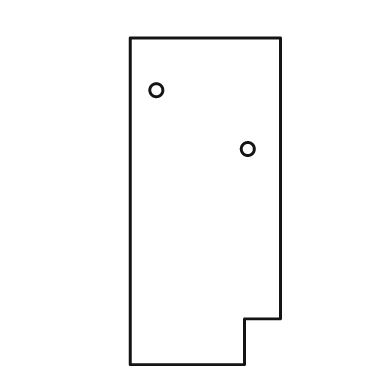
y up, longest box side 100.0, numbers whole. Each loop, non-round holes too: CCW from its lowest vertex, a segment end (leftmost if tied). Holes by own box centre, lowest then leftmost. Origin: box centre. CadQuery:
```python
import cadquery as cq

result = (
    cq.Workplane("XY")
    .moveTo(-23.0, -50.0)
    .lineTo(12.0, -50.0)
    .lineTo(12.0, -36.0)
    .lineTo(23.0, -36.0)
    .lineTo(23.0, 50.0)
    .lineTo(-23.0, 50.0)
    .close()
    .moveTo(13.0, 16.0)
    .circle(2.0)
    .moveTo(-15.0, 34.0)
    .circle(2.0)
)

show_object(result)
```